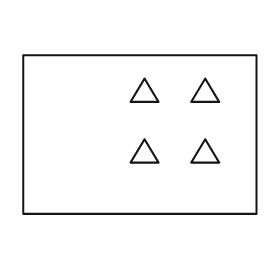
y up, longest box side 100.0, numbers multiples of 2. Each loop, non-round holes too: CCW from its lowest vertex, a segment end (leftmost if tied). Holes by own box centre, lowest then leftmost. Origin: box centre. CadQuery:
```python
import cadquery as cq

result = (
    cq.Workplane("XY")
    .moveTo(-50.0, -34.0)
    .lineTo(50.0, -34.0)
    .lineTo(50.0, 34.0)
    .lineTo(-50.0, 34.0)
    .close()
    .moveTo(-4.0, -12.0)
    .lineTo(8.0, -12.0)
    .lineTo(2.0, -2.0)
    .close()
    .moveTo(22.0, -12.0)
    .lineTo(34.0, -12.0)
    .lineTo(28.0, -2.0)
    .close()
    .moveTo(-4.0, 14.0)
    .lineTo(8.0, 14.0)
    .lineTo(2.0, 24.0)
    .close()
    .moveTo(22.0, 14.0)
    .lineTo(34.0, 14.0)
    .lineTo(28.0, 24.0)
    .close()
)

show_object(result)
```